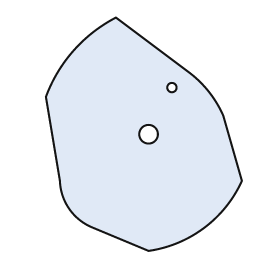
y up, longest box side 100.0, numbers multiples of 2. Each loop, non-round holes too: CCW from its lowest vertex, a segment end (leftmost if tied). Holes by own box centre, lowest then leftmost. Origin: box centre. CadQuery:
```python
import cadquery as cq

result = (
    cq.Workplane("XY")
    .moveTo(2.0, -50.0)
    .threePointArc((26.0, -40.0), (42.0, -20.0))
    .lineTo(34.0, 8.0)
    .threePointArc((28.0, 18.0), (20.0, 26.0))
    .lineTo(-12.0, 50.0)
    .threePointArc((-30.0, 36.0), (-42.0, 16.0))
    .lineTo(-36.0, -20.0)
    .threePointArc((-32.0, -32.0), (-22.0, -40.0))
    .close()
    .moveTo(2.0, 0.0)
    .circle(4.0)
    .moveTo(12.0, 20.0)
    .circle(2.0)
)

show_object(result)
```